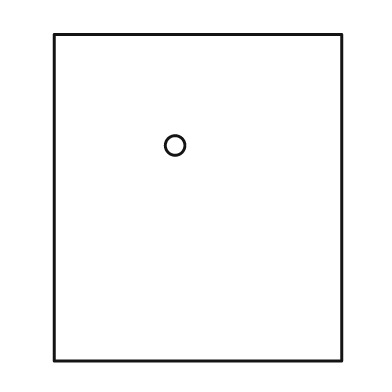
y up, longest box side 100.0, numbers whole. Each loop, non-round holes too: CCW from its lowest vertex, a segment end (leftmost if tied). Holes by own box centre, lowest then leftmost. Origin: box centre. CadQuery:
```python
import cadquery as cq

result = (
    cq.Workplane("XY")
    .moveTo(-44.0, -50.0)
    .lineTo(44.0, -50.0)
    .lineTo(44.0, 50.0)
    .lineTo(-44.0, 50.0)
    .close()
    .moveTo(-7.0, 16.0)
    .circle(3.0)
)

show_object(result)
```